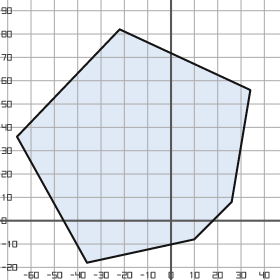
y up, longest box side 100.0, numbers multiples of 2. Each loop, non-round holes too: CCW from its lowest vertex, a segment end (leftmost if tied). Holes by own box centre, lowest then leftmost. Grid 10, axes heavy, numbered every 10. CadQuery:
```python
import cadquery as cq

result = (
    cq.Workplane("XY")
    .moveTo(-36.0, -18.0)
    .lineTo(10.0, -8.0)
    .lineTo(26.0, 8.0)
    .lineTo(34.0, 56.0)
    .lineTo(-22.0, 82.0)
    .lineTo(-66.0, 36.0)
    .close()
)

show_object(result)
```